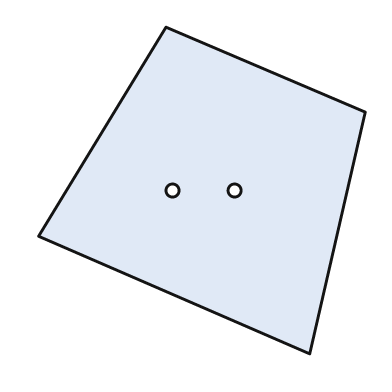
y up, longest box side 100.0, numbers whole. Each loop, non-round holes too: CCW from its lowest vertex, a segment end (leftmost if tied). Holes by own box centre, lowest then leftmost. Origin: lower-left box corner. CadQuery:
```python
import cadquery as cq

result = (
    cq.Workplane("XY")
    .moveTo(83.0, 0.0)
    .lineTo(100.0, 74.0)
    .lineTo(39.0, 100.0)
    .lineTo(0.0, 36.0)
    .close()
    .moveTo(41.0, 50.0)
    .circle(2.0)
    .moveTo(60.0, 50.0)
    .circle(2.0)
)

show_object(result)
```